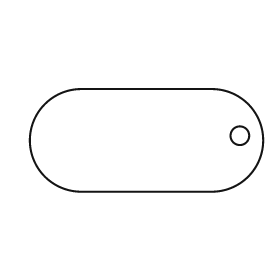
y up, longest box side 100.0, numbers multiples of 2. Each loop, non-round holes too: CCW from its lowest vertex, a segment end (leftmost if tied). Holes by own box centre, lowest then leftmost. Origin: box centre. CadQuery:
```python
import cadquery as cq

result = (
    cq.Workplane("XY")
    .moveTo(-28.0, -22.0)
    .lineTo(28.0, -22.0)
    .threePointArc((50.0, 0.0), (28.0, 22.0))
    .lineTo(-28.0, 22.0)
    .threePointArc((-50.0, 0.0), (-28.0, -22.0))
    .close()
    .moveTo(40.0, 2.0)
    .circle(4.0)
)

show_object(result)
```